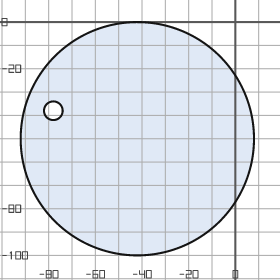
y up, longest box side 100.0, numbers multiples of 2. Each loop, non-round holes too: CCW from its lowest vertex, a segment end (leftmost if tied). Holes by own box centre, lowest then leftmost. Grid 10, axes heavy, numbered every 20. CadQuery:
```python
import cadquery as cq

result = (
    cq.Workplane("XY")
    .moveTo(-42.0, -50.0)
    .circle(50.0)
    .moveTo(-78.0, -38.0)
    .circle(4.0)
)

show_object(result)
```